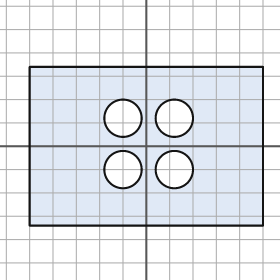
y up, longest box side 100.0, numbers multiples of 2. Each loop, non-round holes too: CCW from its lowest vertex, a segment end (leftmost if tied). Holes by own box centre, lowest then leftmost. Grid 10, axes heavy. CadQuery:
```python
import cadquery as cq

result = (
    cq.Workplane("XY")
    .moveTo(-50.0, -34.0)
    .lineTo(50.0, -34.0)
    .lineTo(50.0, 34.0)
    .lineTo(-50.0, 34.0)
    .close()
    .moveTo(-10.0, -10.0)
    .circle(8.0)
    .moveTo(12.0, -10.0)
    .circle(8.0)
    .moveTo(-10.0, 12.0)
    .circle(8.0)
    .moveTo(12.0, 12.0)
    .circle(8.0)
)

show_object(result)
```